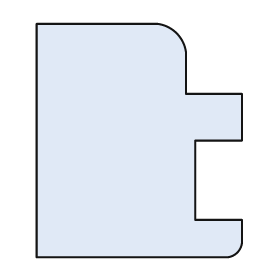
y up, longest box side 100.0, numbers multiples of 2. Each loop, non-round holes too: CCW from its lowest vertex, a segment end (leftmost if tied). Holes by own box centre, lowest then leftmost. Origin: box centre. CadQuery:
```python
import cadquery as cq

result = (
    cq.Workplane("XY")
    .moveTo(-44.0, -50.0)
    .lineTo(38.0, -50.0)
    .threePointArc((42.0, -48.0), (44.0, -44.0))
    .lineTo(44.0, -34.0)
    .lineTo(24.0, -34.0)
    .lineTo(24.0, 0.0)
    .lineTo(44.0, 0.0)
    .lineTo(44.0, 20.0)
    .lineTo(20.0, 20.0)
    .lineTo(20.0, 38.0)
    .threePointArc((16.0, 46.0), (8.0, 50.0))
    .lineTo(-44.0, 50.0)
    .close()
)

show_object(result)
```